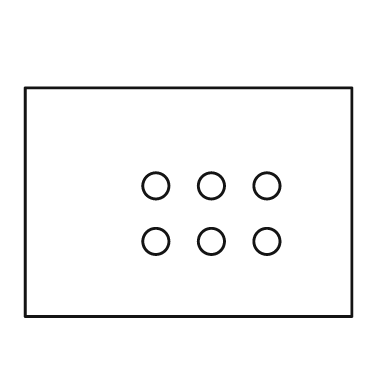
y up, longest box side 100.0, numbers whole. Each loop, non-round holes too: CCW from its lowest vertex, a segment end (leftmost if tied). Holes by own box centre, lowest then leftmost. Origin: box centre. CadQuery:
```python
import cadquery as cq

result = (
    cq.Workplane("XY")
    .moveTo(-50.0, -35.0)
    .lineTo(50.0, -35.0)
    .lineTo(50.0, 35.0)
    .lineTo(-50.0, 35.0)
    .close()
    .moveTo(-10.0, -12.0)
    .circle(4.0)
    .moveTo(7.0, -12.0)
    .circle(4.0)
    .moveTo(24.0, -12.0)
    .circle(4.0)
    .moveTo(-10.0, 5.0)
    .circle(4.0)
    .moveTo(7.0, 5.0)
    .circle(4.0)
    .moveTo(24.0, 5.0)
    .circle(4.0)
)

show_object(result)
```